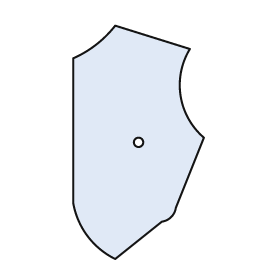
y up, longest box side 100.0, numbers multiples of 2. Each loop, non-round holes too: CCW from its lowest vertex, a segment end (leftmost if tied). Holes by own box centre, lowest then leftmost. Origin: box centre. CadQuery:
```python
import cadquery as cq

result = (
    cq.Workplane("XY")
    .moveTo(-10.0, -50.0)
    .lineTo(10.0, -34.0)
    .threePointArc((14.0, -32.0), (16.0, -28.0))
    .lineTo(28.0, 2.0)
    .threePointArc((18.0, 20.0), (22.0, 40.0))
    .lineTo(-10.0, 50.0)
    .threePointArc((-18.0, 42.0), (-28.0, 36.0))
    .lineTo(-28.0, -26.0)
    .threePointArc((-22.0, -40.0), (-10.0, -50.0))
    .close()
    .moveTo(0.0, 0.0)
    .circle(2.0)
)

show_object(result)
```